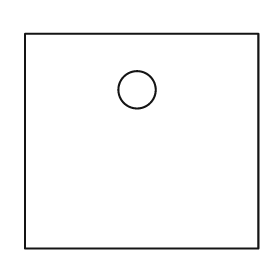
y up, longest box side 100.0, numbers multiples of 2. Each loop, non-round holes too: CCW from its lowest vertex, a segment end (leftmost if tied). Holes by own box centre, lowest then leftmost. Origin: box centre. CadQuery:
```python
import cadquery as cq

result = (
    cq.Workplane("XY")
    .moveTo(-50.0, -46.0)
    .lineTo(50.0, -46.0)
    .lineTo(50.0, 46.0)
    .lineTo(-50.0, 46.0)
    .close()
    .moveTo(-2.0, 22.0)
    .circle(8.0)
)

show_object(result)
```